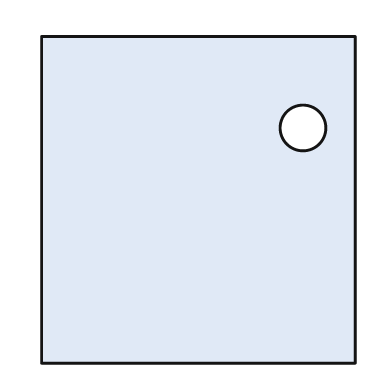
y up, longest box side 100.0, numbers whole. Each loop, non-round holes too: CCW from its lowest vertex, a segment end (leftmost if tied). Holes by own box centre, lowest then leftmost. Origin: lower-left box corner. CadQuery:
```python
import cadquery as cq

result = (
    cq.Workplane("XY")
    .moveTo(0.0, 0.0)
    .lineTo(96.0, 0.0)
    .lineTo(96.0, 100.0)
    .lineTo(0.0, 100.0)
    .close()
    .moveTo(80.0, 72.0)
    .circle(7.0)
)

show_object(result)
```